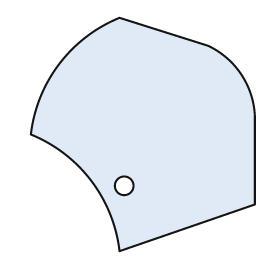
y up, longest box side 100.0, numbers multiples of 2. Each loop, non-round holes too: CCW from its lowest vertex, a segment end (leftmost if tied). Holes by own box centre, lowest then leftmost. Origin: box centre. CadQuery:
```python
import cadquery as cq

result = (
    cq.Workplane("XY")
    .moveTo(-10.0, -50.0)
    .lineTo(48.0, -30.0)
    .lineTo(48.0, 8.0)
    .threePointArc((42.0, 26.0), (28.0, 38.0))
    .lineTo(-10.0, 50.0)
    .threePointArc((-36.0, 30.0), (-48.0, 0.0))
    .threePointArc((-22.0, -20.0), (-10.0, -50.0))
    .close()
    .moveTo(-8.0, -22.0)
    .circle(4.0)
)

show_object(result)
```